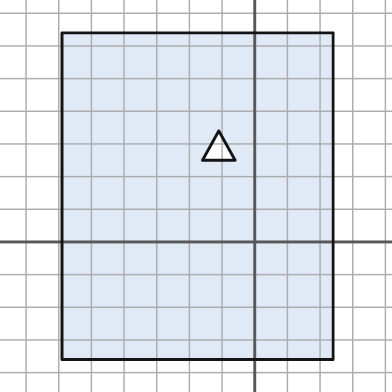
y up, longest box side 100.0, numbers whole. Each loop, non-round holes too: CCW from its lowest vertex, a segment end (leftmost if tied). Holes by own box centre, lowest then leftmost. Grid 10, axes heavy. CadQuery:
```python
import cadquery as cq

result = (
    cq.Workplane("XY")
    .moveTo(-59.0, -36.0)
    .lineTo(24.0, -36.0)
    .lineTo(24.0, 64.0)
    .lineTo(-59.0, 64.0)
    .close()
    .moveTo(-16.0, 25.0)
    .lineTo(-6.0, 25.0)
    .lineTo(-11.0, 34.0)
    .close()
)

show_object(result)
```